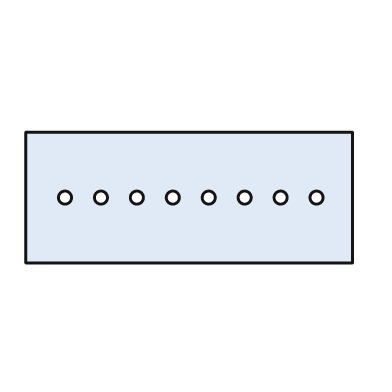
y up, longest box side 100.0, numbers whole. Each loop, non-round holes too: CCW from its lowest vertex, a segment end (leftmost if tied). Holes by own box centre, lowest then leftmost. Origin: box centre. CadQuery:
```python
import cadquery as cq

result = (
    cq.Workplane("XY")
    .moveTo(-50.0, -20.0)
    .lineTo(50.0, -20.0)
    .lineTo(50.0, 20.0)
    .lineTo(-50.0, 20.0)
    .close()
    .moveTo(-38.0, 0.0)
    .circle(2.0)
    .moveTo(-27.0, 0.0)
    .circle(2.0)
    .moveTo(-16.0, 0.0)
    .circle(2.0)
    .moveTo(-5.0, 0.0)
    .circle(2.0)
    .moveTo(6.0, 0.0)
    .circle(2.0)
    .moveTo(17.0, 0.0)
    .circle(2.0)
    .moveTo(28.0, 0.0)
    .circle(2.0)
    .moveTo(39.0, 0.0)
    .circle(2.0)
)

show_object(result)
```